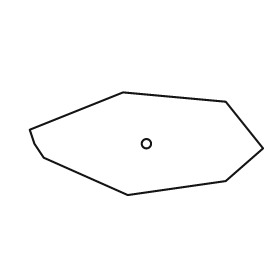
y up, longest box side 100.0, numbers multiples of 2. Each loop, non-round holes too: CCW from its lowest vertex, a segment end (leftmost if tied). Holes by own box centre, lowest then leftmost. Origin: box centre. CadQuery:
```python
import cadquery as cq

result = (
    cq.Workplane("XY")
    .moveTo(-8.0, -22.0)
    .lineTo(34.0, -16.0)
    .lineTo(50.0, -2.0)
    .lineTo(34.0, 18.0)
    .lineTo(-10.0, 22.0)
    .lineTo(-50.0, 6.0)
    .lineTo(-48.0, 0.0)
    .lineTo(-44.0, -6.0)
    .close()
    .moveTo(0.0, 0.0)
    .circle(2.0)
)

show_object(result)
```